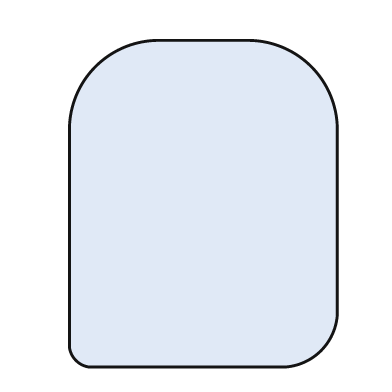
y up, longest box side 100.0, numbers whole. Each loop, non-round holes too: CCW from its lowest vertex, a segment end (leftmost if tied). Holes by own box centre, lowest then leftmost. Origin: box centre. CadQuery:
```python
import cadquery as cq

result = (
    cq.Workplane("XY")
    .moveTo(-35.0, -50.0)
    .lineTo(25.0, -50.0)
    .threePointArc((36.0, -45.0), (41.0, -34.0))
    .lineTo(41.0, 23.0)
    .threePointArc((33.0, 42.0), (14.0, 50.0))
    .lineTo(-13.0, 50.0)
    .threePointArc((-33.0, 42.0), (-41.0, 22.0))
    .lineTo(-41.0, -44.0)
    .threePointArc((-39.0, -48.0), (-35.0, -50.0))
    .close()
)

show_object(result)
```